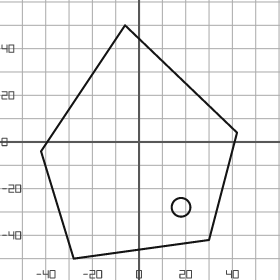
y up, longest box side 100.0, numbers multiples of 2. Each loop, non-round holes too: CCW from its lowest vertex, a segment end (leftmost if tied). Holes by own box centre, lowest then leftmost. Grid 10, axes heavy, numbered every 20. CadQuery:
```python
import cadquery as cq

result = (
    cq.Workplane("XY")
    .moveTo(-28.0, -50.0)
    .lineTo(30.0, -42.0)
    .lineTo(42.0, 4.0)
    .lineTo(-6.0, 50.0)
    .lineTo(-42.0, -4.0)
    .close()
    .moveTo(18.0, -28.0)
    .circle(4.0)
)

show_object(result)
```